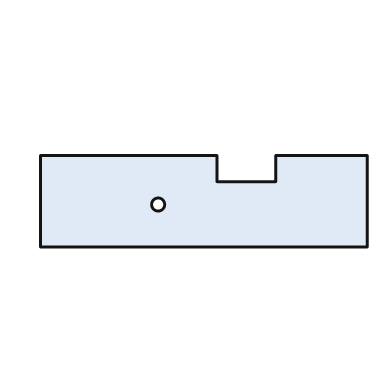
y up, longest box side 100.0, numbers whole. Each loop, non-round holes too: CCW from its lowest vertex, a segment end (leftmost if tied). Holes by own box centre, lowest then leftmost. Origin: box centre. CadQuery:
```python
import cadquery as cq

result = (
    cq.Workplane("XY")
    .moveTo(-50.0, -14.0)
    .lineTo(50.0, -14.0)
    .lineTo(50.0, 14.0)
    .lineTo(22.0, 14.0)
    .lineTo(22.0, 6.0)
    .lineTo(4.0, 6.0)
    .lineTo(4.0, 14.0)
    .lineTo(-50.0, 14.0)
    .close()
    .moveTo(-14.0, -1.0)
    .circle(2.0)
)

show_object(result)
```